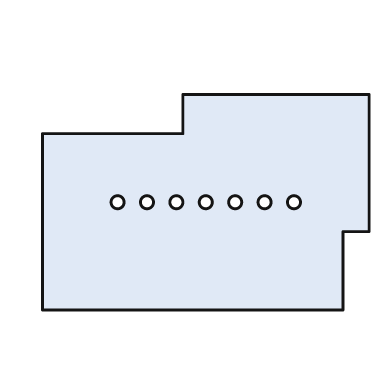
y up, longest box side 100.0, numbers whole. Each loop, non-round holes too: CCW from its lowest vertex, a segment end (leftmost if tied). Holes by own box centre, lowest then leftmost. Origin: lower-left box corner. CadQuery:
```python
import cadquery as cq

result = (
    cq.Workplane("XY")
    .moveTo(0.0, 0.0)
    .lineTo(92.0, 0.0)
    .lineTo(92.0, 24.0)
    .lineTo(100.0, 24.0)
    .lineTo(100.0, 66.0)
    .lineTo(43.0, 66.0)
    .lineTo(43.0, 54.0)
    .lineTo(0.0, 54.0)
    .close()
    .moveTo(23.0, 33.0)
    .circle(2.0)
    .moveTo(32.0, 33.0)
    .circle(2.0)
    .moveTo(41.0, 33.0)
    .circle(2.0)
    .moveTo(50.0, 33.0)
    .circle(2.0)
    .moveTo(59.0, 33.0)
    .circle(2.0)
    .moveTo(68.0, 33.0)
    .circle(2.0)
    .moveTo(77.0, 33.0)
    .circle(2.0)
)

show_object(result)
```